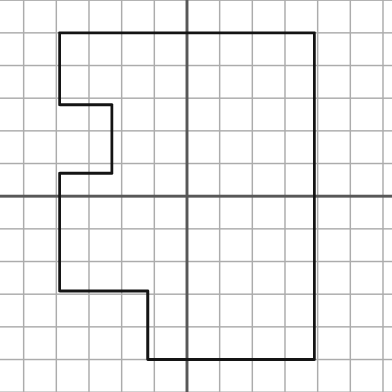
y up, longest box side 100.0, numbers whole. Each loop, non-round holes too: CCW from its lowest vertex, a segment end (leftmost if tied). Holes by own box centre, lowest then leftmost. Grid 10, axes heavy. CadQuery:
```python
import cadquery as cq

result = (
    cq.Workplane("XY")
    .moveTo(-12.0, -50.0)
    .lineTo(39.0, -50.0)
    .lineTo(39.0, 50.0)
    .lineTo(-39.0, 50.0)
    .lineTo(-39.0, 28.0)
    .lineTo(-23.0, 28.0)
    .lineTo(-23.0, 7.0)
    .lineTo(-39.0, 7.0)
    .lineTo(-39.0, -29.0)
    .lineTo(-12.0, -29.0)
    .close()
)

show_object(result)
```